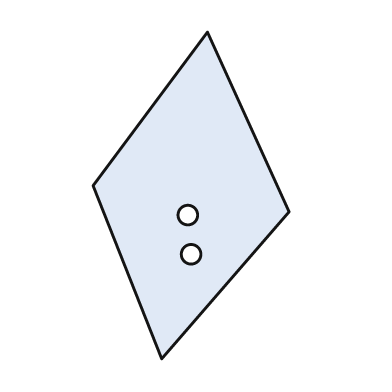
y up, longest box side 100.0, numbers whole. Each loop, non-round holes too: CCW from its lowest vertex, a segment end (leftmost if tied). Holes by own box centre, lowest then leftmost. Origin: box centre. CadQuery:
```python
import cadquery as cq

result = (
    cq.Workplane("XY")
    .moveTo(-9.0, -50.0)
    .lineTo(30.0, -5.0)
    .lineTo(5.0, 50.0)
    .lineTo(-30.0, 3.0)
    .close()
    .moveTo(0.0, -18.0)
    .circle(3.0)
    .moveTo(-1.0, -6.0)
    .circle(3.0)
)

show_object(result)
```